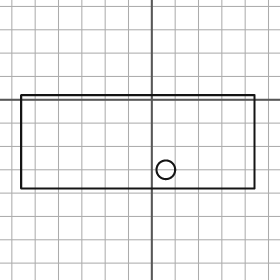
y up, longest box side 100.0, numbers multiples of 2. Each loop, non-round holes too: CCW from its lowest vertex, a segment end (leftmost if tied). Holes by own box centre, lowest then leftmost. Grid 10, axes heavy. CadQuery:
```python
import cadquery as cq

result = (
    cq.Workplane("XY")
    .moveTo(-56.0, -38.0)
    .lineTo(44.0, -38.0)
    .lineTo(44.0, 2.0)
    .lineTo(-56.0, 2.0)
    .close()
    .moveTo(6.0, -30.0)
    .circle(4.0)
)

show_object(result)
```